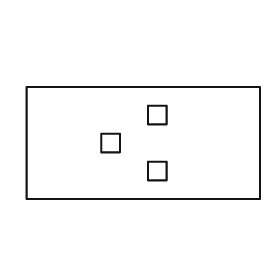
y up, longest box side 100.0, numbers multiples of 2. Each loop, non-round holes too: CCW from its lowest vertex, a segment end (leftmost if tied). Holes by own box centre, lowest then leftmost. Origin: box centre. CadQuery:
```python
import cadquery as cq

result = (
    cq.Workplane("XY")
    .moveTo(-50.0, -24.0)
    .lineTo(50.0, -24.0)
    .lineTo(50.0, 24.0)
    .lineTo(-50.0, 24.0)
    .close()
    .moveTo(2.0, -16.0)
    .lineTo(10.0, -16.0)
    .lineTo(10.0, -8.0)
    .lineTo(2.0, -8.0)
    .close()
    .moveTo(-18.0, -4.0)
    .lineTo(-10.0, -4.0)
    .lineTo(-10.0, 4.0)
    .lineTo(-18.0, 4.0)
    .close()
    .moveTo(2.0, 8.0)
    .lineTo(10.0, 8.0)
    .lineTo(10.0, 16.0)
    .lineTo(2.0, 16.0)
    .close()
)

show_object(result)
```